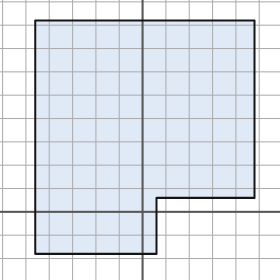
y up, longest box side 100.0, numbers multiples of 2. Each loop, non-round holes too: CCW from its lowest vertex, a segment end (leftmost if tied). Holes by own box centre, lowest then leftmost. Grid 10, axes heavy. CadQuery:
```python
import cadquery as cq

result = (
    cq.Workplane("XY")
    .moveTo(-46.0, -18.0)
    .lineTo(6.0, -18.0)
    .lineTo(6.0, 6.0)
    .lineTo(48.0, 6.0)
    .lineTo(48.0, 82.0)
    .lineTo(-46.0, 82.0)
    .close()
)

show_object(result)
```